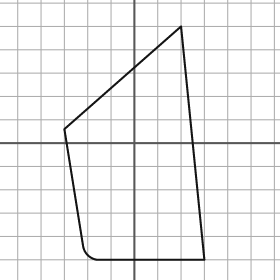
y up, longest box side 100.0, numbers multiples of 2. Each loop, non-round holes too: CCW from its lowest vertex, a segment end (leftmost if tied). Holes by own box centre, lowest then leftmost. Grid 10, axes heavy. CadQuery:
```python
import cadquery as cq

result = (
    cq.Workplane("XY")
    .moveTo(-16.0, -50.0)
    .lineTo(30.0, -50.0)
    .lineTo(20.0, 50.0)
    .lineTo(-30.0, 6.0)
    .lineTo(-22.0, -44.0)
    .threePointArc((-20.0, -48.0), (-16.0, -50.0))
    .close()
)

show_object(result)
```